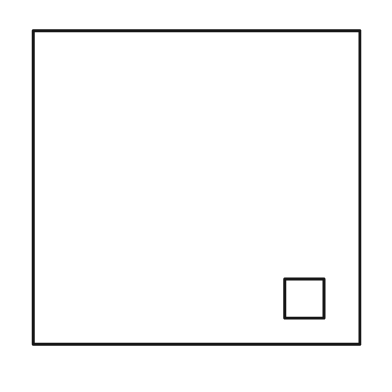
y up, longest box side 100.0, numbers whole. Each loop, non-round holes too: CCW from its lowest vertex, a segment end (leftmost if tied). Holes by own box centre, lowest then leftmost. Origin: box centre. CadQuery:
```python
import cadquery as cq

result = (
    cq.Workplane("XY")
    .moveTo(-50.0, -48.0)
    .lineTo(50.0, -48.0)
    .lineTo(50.0, 48.0)
    .lineTo(-50.0, 48.0)
    .close()
    .moveTo(27.0, -40.0)
    .lineTo(39.0, -40.0)
    .lineTo(39.0, -28.0)
    .lineTo(27.0, -28.0)
    .close()
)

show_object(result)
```